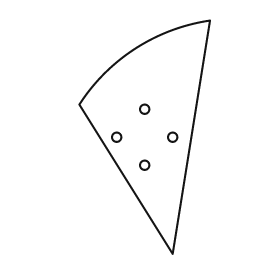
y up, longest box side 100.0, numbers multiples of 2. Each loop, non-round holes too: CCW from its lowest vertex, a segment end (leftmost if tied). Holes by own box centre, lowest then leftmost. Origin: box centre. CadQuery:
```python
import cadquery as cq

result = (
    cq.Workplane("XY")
    .moveTo(12.0, -50.0)
    .lineTo(28.0, 50.0)
    .threePointArc((-4.0, 38.0), (-28.0, 14.0))
    .close()
    .moveTo(0.0, -12.0)
    .circle(2.0)
    .moveTo(-12.0, 0.0)
    .circle(2.0)
    .moveTo(12.0, 0.0)
    .circle(2.0)
    .moveTo(0.0, 12.0)
    .circle(2.0)
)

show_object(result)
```